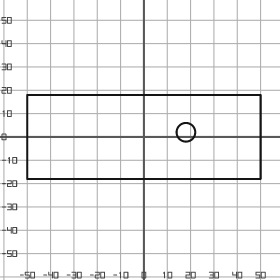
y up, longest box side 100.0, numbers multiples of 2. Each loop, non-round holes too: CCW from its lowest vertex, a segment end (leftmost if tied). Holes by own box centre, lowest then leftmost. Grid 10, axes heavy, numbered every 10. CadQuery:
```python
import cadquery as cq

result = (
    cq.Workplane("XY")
    .moveTo(-50.0, -18.0)
    .lineTo(50.0, -18.0)
    .lineTo(50.0, 18.0)
    .lineTo(-50.0, 18.0)
    .close()
    .moveTo(18.0, 2.0)
    .circle(4.0)
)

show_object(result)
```